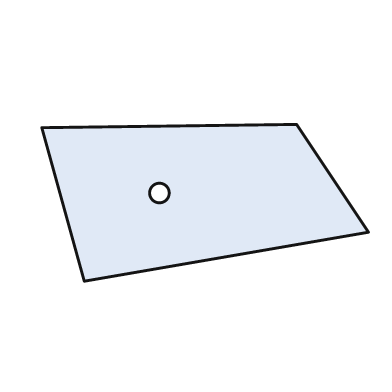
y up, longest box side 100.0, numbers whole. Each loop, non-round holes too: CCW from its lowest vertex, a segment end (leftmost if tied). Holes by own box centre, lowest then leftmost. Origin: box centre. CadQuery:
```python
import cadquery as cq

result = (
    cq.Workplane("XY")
    .moveTo(-37.0, -24.0)
    .lineTo(50.0, -9.0)
    .lineTo(28.0, 24.0)
    .lineTo(-50.0, 23.0)
    .close()
    .moveTo(-14.0, 3.0)
    .circle(3.0)
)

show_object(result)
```